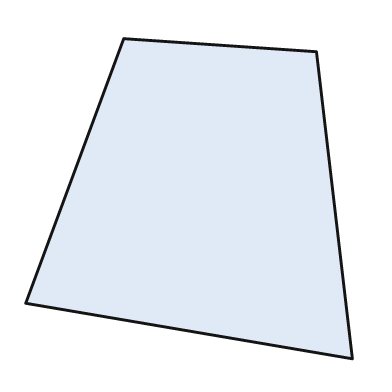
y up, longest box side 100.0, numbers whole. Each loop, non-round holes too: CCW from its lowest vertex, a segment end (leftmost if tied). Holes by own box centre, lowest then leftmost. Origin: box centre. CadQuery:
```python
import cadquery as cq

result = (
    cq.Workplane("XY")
    .moveTo(50.0, -49.0)
    .lineTo(39.0, 45.0)
    .lineTo(-20.0, 49.0)
    .lineTo(-50.0, -32.0)
    .close()
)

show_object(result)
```